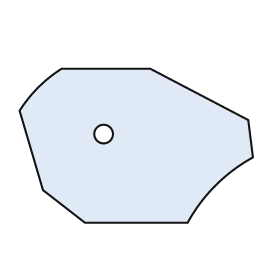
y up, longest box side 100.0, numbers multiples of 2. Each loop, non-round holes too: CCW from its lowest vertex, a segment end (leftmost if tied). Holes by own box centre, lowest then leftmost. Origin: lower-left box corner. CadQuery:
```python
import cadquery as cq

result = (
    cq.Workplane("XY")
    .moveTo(28.0, 0.0)
    .lineTo(72.0, 0.0)
    .threePointArc((84.0, 16.0), (100.0, 28.0))
    .lineTo(98.0, 44.0)
    .lineTo(56.0, 66.0)
    .lineTo(18.0, 66.0)
    .threePointArc((8.0, 58.0), (0.0, 48.0))
    .lineTo(10.0, 14.0)
    .close()
    .moveTo(36.0, 38.0)
    .circle(4.0)
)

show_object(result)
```